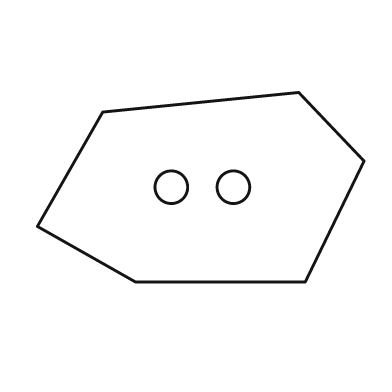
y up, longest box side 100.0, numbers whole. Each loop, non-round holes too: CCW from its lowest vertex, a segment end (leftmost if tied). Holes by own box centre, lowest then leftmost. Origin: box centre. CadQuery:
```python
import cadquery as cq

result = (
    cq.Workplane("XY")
    .moveTo(-20.0, -29.0)
    .lineTo(32.0, -29.0)
    .lineTo(50.0, 8.0)
    .lineTo(30.0, 29.0)
    .lineTo(-30.0, 23.0)
    .lineTo(-50.0, -12.0)
    .close()
    .moveTo(-9.0, 0.0)
    .circle(5.0)
    .moveTo(10.0, 0.0)
    .circle(5.0)
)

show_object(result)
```